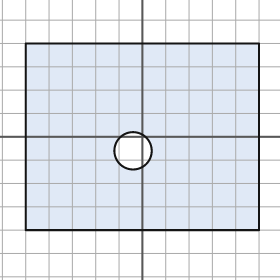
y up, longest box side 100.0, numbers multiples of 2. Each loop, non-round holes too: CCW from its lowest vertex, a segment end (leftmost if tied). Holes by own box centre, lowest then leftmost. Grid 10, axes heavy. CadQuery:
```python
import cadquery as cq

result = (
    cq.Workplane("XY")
    .moveTo(-50.0, -40.0)
    .lineTo(50.0, -40.0)
    .lineTo(50.0, 40.0)
    .lineTo(-50.0, 40.0)
    .close()
    .moveTo(-4.0, -6.0)
    .circle(8.0)
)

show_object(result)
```